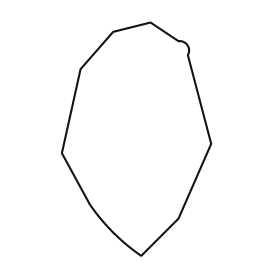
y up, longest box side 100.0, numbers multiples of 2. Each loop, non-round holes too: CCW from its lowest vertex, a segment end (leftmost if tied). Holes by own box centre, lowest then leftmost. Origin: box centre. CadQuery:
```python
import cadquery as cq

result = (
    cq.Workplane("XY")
    .moveTo(2.0, -50.0)
    .lineTo(18.0, -34.0)
    .lineTo(32.0, -2.0)
    .lineTo(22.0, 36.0)
    .threePointArc((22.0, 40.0), (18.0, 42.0))
    .lineTo(6.0, 50.0)
    .lineTo(-10.0, 46.0)
    .lineTo(-24.0, 30.0)
    .lineTo(-32.0, -6.0)
    .lineTo(-20.0, -28.0)
    .threePointArc((-10.0, -40.0), (2.0, -50.0))
    .close()
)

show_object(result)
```